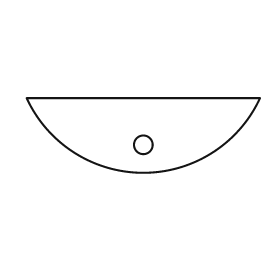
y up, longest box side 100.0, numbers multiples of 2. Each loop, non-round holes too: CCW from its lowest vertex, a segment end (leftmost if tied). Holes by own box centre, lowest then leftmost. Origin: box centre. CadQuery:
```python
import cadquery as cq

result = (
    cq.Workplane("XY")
    .moveTo(-50.0, 16.0)
    .threePointArc((0.0, -16.0), (50.0, 16.0))
    .close()
    .moveTo(0.0, -4.0)
    .circle(4.0)
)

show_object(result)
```